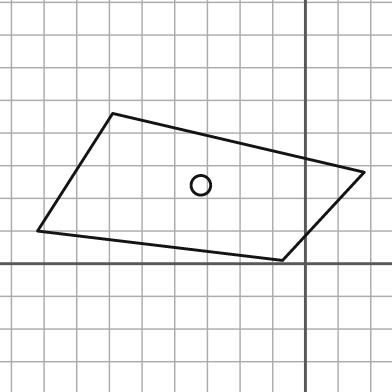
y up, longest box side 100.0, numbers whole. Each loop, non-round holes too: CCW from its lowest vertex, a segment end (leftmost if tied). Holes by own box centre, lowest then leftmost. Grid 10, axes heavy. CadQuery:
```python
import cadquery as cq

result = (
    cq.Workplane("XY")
    .moveTo(-7.0, 1.0)
    .lineTo(18.0, 28.0)
    .lineTo(-59.0, 46.0)
    .lineTo(-82.0, 10.0)
    .close()
    .moveTo(-32.0, 24.0)
    .circle(3.0)
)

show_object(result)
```